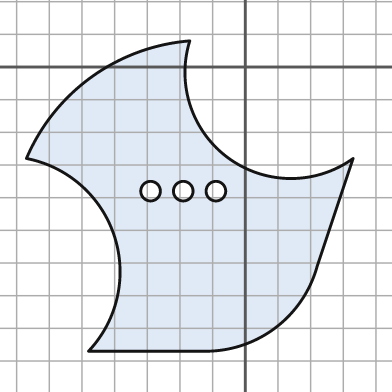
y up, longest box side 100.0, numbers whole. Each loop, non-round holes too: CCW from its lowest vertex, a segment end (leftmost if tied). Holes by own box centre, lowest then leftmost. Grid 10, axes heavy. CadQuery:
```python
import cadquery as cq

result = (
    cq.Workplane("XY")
    .moveTo(-48.0, -87.0)
    .lineTo(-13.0, -87.0)
    .threePointArc((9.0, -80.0), (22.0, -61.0))
    .lineTo(33.0, -28.0)
    .threePointArc((-5.0, -28.0), (-17.0, 8.0))
    .threePointArc((-47.0, -3.0), (-67.0, -28.0))
    .threePointArc((-40.0, -52.0), (-48.0, -87.0))
    .close()
    .moveTo(-29.0, -38.0)
    .circle(3.0)
    .moveTo(-19.0, -38.0)
    .circle(3.0)
    .moveTo(-9.0, -38.0)
    .circle(3.0)
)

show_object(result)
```